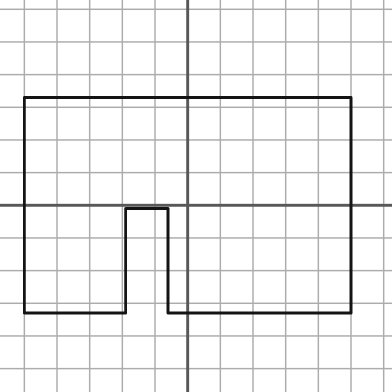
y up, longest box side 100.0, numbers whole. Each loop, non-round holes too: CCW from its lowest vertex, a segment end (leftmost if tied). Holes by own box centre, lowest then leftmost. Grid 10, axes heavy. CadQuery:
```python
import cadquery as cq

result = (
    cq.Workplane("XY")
    .moveTo(-50.0, -33.0)
    .lineTo(-19.0, -33.0)
    .lineTo(-19.0, -1.0)
    .lineTo(-6.0, -1.0)
    .lineTo(-6.0, -33.0)
    .lineTo(50.0, -33.0)
    .lineTo(50.0, 33.0)
    .lineTo(-50.0, 33.0)
    .close()
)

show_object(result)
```